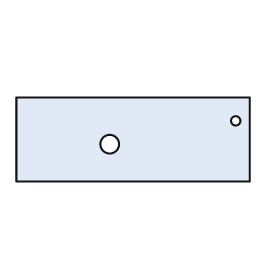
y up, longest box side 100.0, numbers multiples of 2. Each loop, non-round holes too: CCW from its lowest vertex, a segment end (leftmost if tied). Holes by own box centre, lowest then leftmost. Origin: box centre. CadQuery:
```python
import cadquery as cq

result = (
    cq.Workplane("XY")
    .moveTo(-50.0, -18.0)
    .lineTo(50.0, -18.0)
    .lineTo(50.0, 18.0)
    .lineTo(-50.0, 18.0)
    .close()
    .moveTo(-10.0, -2.0)
    .circle(4.0)
    .moveTo(44.0, 8.0)
    .circle(2.0)
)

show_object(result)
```